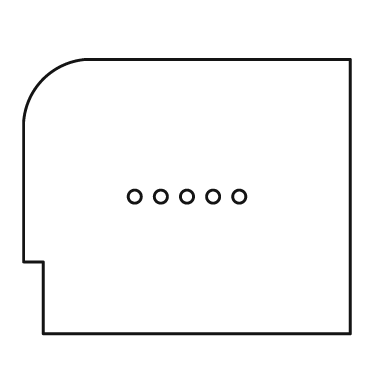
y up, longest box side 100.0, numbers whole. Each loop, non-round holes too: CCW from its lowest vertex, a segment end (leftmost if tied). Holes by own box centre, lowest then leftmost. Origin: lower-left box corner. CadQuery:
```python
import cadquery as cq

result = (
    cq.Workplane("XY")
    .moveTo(6.0, 0.0)
    .lineTo(100.0, 0.0)
    .lineTo(100.0, 84.0)
    .lineTo(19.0, 84.0)
    .threePointArc((6.0, 78.0), (0.0, 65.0))
    .lineTo(0.0, 22.0)
    .lineTo(6.0, 22.0)
    .close()
    .moveTo(34.0, 42.0)
    .circle(2.0)
    .moveTo(42.0, 42.0)
    .circle(2.0)
    .moveTo(50.0, 42.0)
    .circle(2.0)
    .moveTo(58.0, 42.0)
    .circle(2.0)
    .moveTo(66.0, 42.0)
    .circle(2.0)
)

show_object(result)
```